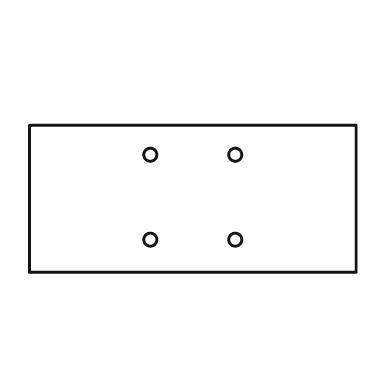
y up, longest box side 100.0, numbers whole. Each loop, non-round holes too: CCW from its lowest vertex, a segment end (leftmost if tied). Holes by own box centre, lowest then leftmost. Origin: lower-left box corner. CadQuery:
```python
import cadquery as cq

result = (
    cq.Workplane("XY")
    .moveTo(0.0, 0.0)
    .lineTo(100.0, 0.0)
    .lineTo(100.0, 45.0)
    .lineTo(0.0, 45.0)
    .close()
    .moveTo(37.0, 10.0)
    .circle(2.0)
    .moveTo(63.0, 10.0)
    .circle(2.0)
    .moveTo(37.0, 36.0)
    .circle(2.0)
    .moveTo(63.0, 36.0)
    .circle(2.0)
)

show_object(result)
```